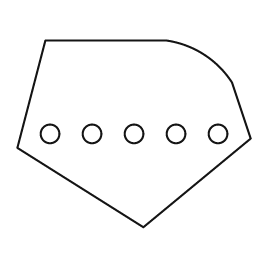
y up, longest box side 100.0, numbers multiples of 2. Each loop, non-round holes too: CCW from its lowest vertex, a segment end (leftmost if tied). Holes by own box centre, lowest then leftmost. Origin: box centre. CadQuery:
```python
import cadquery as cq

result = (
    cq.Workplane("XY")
    .moveTo(4.0, -40.0)
    .lineTo(50.0, -2.0)
    .lineTo(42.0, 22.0)
    .threePointArc((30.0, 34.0), (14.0, 40.0))
    .lineTo(-38.0, 40.0)
    .lineTo(-50.0, -6.0)
    .close()
    .moveTo(-36.0, 0.0)
    .circle(4.0)
    .moveTo(-18.0, 0.0)
    .circle(4.0)
    .moveTo(0.0, 0.0)
    .circle(4.0)
    .moveTo(18.0, 0.0)
    .circle(4.0)
    .moveTo(36.0, 0.0)
    .circle(4.0)
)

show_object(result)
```